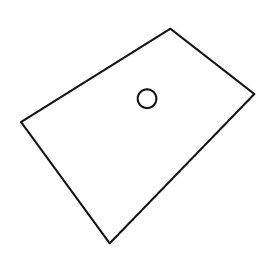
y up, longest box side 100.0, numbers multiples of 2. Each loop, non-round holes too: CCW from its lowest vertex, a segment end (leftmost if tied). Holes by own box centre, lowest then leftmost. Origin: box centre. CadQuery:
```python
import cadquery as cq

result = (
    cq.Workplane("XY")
    .moveTo(-12.0, -46.0)
    .lineTo(50.0, 18.0)
    .lineTo(14.0, 46.0)
    .lineTo(-50.0, 6.0)
    .close()
    .moveTo(4.0, 16.0)
    .circle(4.0)
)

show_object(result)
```